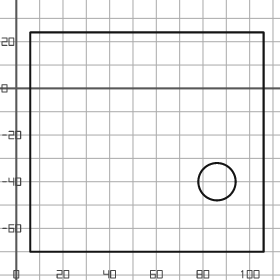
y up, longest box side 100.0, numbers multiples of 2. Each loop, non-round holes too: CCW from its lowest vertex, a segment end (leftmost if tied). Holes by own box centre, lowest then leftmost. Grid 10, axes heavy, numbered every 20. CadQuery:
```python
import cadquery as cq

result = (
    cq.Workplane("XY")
    .moveTo(6.0, -70.0)
    .lineTo(106.0, -70.0)
    .lineTo(106.0, 24.0)
    .lineTo(6.0, 24.0)
    .close()
    .moveTo(86.0, -40.0)
    .circle(8.0)
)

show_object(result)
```